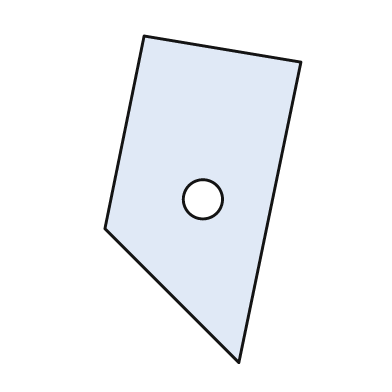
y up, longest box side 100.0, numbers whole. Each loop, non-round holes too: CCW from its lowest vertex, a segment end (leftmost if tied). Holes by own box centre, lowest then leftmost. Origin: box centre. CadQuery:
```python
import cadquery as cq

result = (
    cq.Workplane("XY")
    .moveTo(11.0, -50.0)
    .lineTo(30.0, 42.0)
    .lineTo(-18.0, 50.0)
    .lineTo(-30.0, -9.0)
    .close()
    .moveTo(0.0, 0.0)
    .circle(6.0)
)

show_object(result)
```